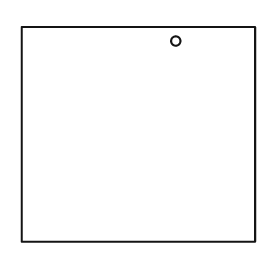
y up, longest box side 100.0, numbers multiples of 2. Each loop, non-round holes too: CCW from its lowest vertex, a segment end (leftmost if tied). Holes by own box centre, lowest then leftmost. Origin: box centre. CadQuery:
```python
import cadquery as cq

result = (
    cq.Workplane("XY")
    .moveTo(-50.0, -46.0)
    .lineTo(50.0, -46.0)
    .lineTo(50.0, 46.0)
    .lineTo(-50.0, 46.0)
    .close()
    .moveTo(16.0, 40.0)
    .circle(2.0)
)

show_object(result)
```